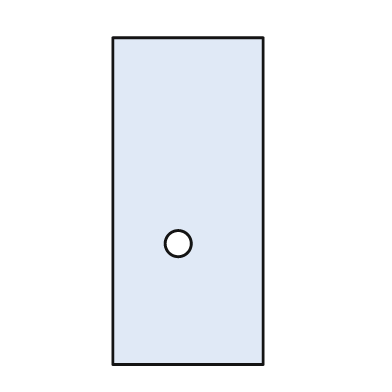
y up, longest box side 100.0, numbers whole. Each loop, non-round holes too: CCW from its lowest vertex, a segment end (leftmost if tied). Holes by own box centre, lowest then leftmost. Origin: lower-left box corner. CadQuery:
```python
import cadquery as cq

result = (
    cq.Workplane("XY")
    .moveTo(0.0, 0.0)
    .lineTo(46.0, 0.0)
    .lineTo(46.0, 100.0)
    .lineTo(0.0, 100.0)
    .close()
    .moveTo(20.0, 37.0)
    .circle(4.0)
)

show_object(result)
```